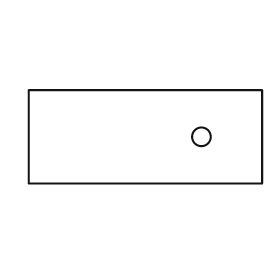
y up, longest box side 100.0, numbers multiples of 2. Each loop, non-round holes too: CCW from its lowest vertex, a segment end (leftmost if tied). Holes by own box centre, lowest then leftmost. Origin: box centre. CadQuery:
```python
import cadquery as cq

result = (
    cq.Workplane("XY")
    .moveTo(-50.0, -20.0)
    .lineTo(50.0, -20.0)
    .lineTo(50.0, 20.0)
    .lineTo(-50.0, 20.0)
    .close()
    .moveTo(24.0, 0.0)
    .circle(4.0)
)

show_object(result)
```